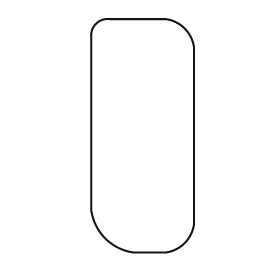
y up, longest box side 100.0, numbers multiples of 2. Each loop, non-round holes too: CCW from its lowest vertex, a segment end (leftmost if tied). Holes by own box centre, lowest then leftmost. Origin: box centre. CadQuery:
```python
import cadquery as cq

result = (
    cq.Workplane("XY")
    .moveTo(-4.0, -50.0)
    .lineTo(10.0, -50.0)
    .threePointArc((18.0, -46.0), (22.0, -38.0))
    .lineTo(22.0, 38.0)
    .threePointArc((18.0, 46.0), (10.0, 50.0))
    .lineTo(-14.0, 50.0)
    .threePointArc((-20.0, 48.0), (-22.0, 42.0))
    .lineTo(-22.0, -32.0)
    .threePointArc((-16.0, -44.0), (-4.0, -50.0))
    .close()
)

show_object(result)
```